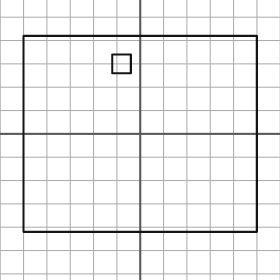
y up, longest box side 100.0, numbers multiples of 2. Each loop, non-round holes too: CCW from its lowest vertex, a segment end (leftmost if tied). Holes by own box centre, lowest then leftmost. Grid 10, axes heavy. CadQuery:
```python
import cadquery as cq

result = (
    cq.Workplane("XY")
    .moveTo(-50.0, -42.0)
    .lineTo(50.0, -42.0)
    .lineTo(50.0, 42.0)
    .lineTo(-50.0, 42.0)
    .close()
    .moveTo(-12.0, 26.0)
    .lineTo(-4.0, 26.0)
    .lineTo(-4.0, 34.0)
    .lineTo(-12.0, 34.0)
    .close()
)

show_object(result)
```